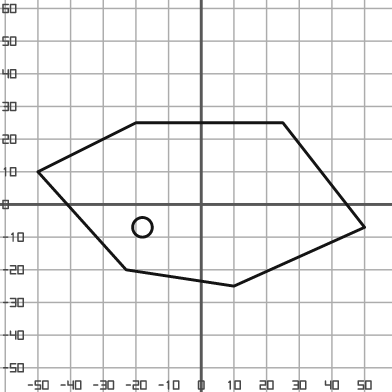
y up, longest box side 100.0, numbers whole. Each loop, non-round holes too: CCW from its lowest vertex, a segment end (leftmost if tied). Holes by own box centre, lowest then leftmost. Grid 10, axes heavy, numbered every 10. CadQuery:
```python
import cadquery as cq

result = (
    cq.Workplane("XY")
    .moveTo(10.0, -25.0)
    .lineTo(50.0, -7.0)
    .lineTo(25.0, 25.0)
    .lineTo(-20.0, 25.0)
    .lineTo(-50.0, 10.0)
    .lineTo(-23.0, -20.0)
    .close()
    .moveTo(-18.0, -7.0)
    .circle(3.0)
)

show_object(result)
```